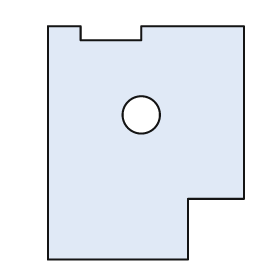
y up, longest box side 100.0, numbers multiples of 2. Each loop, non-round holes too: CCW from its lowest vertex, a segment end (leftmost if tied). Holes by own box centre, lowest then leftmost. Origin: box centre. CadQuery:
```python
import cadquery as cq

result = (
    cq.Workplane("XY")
    .moveTo(-42.0, -50.0)
    .lineTo(18.0, -50.0)
    .lineTo(18.0, -24.0)
    .lineTo(42.0, -24.0)
    .lineTo(42.0, 50.0)
    .lineTo(-2.0, 50.0)
    .lineTo(-2.0, 44.0)
    .lineTo(-28.0, 44.0)
    .lineTo(-28.0, 50.0)
    .lineTo(-42.0, 50.0)
    .close()
    .moveTo(-2.0, 12.0)
    .circle(8.0)
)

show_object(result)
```